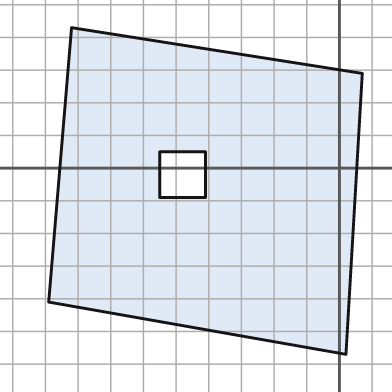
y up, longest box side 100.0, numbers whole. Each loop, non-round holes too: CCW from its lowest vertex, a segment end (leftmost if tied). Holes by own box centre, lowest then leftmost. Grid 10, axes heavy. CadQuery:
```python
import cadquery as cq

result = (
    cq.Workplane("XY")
    .moveTo(2.0, -57.0)
    .lineTo(7.0, 29.0)
    .lineTo(-82.0, 43.0)
    .lineTo(-89.0, -41.0)
    .close()
    .moveTo(-55.0, -9.0)
    .lineTo(-41.0, -9.0)
    .lineTo(-41.0, 5.0)
    .lineTo(-55.0, 5.0)
    .close()
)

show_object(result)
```